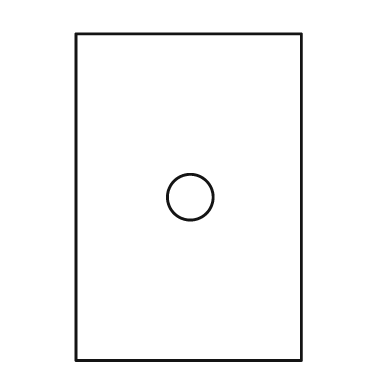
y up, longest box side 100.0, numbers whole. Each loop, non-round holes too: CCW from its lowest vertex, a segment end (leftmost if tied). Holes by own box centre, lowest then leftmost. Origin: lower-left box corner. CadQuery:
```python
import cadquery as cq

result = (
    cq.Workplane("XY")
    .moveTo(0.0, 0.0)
    .lineTo(69.0, 0.0)
    .lineTo(69.0, 100.0)
    .lineTo(0.0, 100.0)
    .close()
    .moveTo(35.0, 50.0)
    .circle(7.0)
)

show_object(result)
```